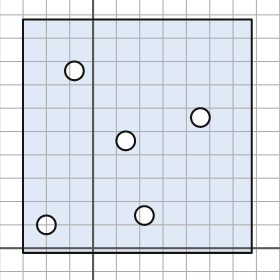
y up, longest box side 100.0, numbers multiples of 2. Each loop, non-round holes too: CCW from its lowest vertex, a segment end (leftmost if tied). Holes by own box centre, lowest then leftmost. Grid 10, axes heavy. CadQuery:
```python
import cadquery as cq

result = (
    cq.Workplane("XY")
    .moveTo(-30.0, -2.0)
    .lineTo(68.0, -2.0)
    .lineTo(68.0, 98.0)
    .lineTo(-30.0, 98.0)
    .close()
    .moveTo(-20.0, 10.0)
    .circle(4.0)
    .moveTo(22.0, 14.0)
    .circle(4.0)
    .moveTo(14.0, 46.0)
    .circle(4.0)
    .moveTo(46.0, 56.0)
    .circle(4.0)
    .moveTo(-8.0, 76.0)
    .circle(4.0)
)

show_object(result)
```